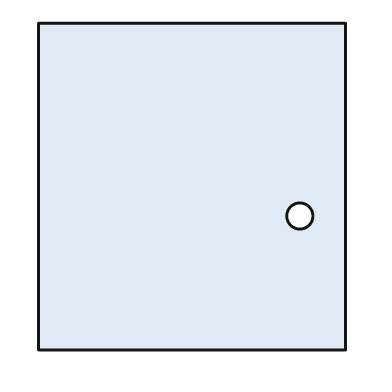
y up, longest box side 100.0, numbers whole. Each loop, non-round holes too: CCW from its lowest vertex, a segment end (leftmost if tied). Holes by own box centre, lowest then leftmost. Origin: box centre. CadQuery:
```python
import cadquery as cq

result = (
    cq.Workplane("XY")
    .moveTo(-47.0, -50.0)
    .lineTo(47.0, -50.0)
    .lineTo(47.0, 50.0)
    .lineTo(-47.0, 50.0)
    .close()
    .moveTo(33.0, -9.0)
    .circle(4.0)
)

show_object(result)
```